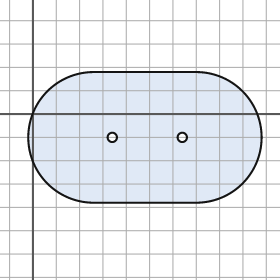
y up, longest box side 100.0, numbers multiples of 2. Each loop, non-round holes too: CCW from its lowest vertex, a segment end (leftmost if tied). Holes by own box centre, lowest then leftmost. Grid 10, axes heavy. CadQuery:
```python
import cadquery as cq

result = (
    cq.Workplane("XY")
    .moveTo(26.0, -38.0)
    .lineTo(70.0, -38.0)
    .threePointArc((98.0, -10.0), (70.0, 18.0))
    .lineTo(26.0, 18.0)
    .threePointArc((-2.0, -10.0), (26.0, -38.0))
    .close()
    .moveTo(34.0, -10.0)
    .circle(2.0)
    .moveTo(64.0, -10.0)
    .circle(2.0)
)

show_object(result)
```